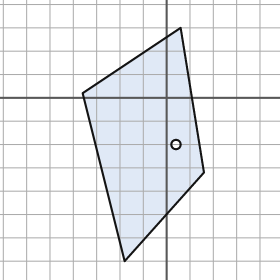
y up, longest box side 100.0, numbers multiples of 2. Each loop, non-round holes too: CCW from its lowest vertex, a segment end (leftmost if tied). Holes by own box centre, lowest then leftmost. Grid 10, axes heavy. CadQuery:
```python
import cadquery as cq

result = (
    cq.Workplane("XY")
    .moveTo(-18.0, -70.0)
    .lineTo(16.0, -32.0)
    .lineTo(6.0, 30.0)
    .lineTo(-36.0, 2.0)
    .close()
    .moveTo(4.0, -20.0)
    .circle(2.0)
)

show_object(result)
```